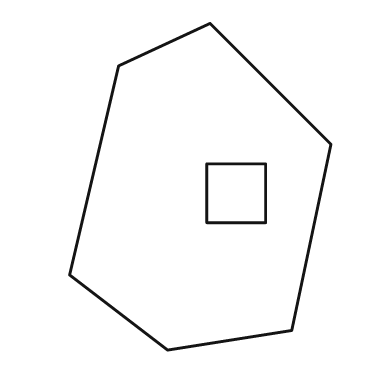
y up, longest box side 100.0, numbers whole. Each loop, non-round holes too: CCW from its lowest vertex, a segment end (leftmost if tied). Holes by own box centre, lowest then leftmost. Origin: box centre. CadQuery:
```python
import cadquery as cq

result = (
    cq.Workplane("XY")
    .moveTo(-10.0, -50.0)
    .lineTo(28.0, -44.0)
    .lineTo(40.0, 13.0)
    .lineTo(3.0, 50.0)
    .lineTo(-25.0, 37.0)
    .lineTo(-40.0, -27.0)
    .close()
    .moveTo(2.0, -11.0)
    .lineTo(20.0, -11.0)
    .lineTo(20.0, 7.0)
    .lineTo(2.0, 7.0)
    .close()
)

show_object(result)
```